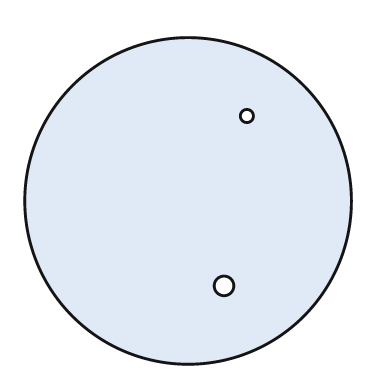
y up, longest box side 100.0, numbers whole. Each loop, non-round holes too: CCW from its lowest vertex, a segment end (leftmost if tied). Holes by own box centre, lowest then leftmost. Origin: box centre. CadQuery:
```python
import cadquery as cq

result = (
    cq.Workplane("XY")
    .moveTo(0.0, 0.0)
    .circle(50.0)
    .moveTo(11.0, -26.0)
    .circle(3.0)
    .moveTo(18.0, 26.0)
    .circle(2.0)
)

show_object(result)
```